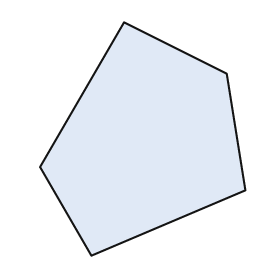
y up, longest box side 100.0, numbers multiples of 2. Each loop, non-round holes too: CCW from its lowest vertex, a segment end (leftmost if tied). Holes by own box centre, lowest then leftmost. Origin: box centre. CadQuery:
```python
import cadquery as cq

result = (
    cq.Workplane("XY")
    .moveTo(-22.0, -50.0)
    .lineTo(44.0, -22.0)
    .lineTo(36.0, 28.0)
    .lineTo(-8.0, 50.0)
    .lineTo(-44.0, -12.0)
    .close()
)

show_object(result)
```